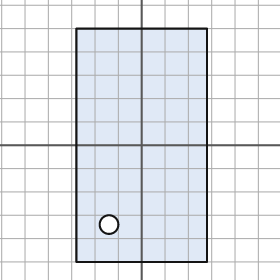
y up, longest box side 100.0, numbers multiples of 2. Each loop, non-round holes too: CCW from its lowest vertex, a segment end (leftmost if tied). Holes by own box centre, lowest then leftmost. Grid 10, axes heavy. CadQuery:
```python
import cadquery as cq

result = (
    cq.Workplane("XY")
    .moveTo(-28.0, -50.0)
    .lineTo(28.0, -50.0)
    .lineTo(28.0, 50.0)
    .lineTo(-28.0, 50.0)
    .close()
    .moveTo(-14.0, -34.0)
    .circle(4.0)
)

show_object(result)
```